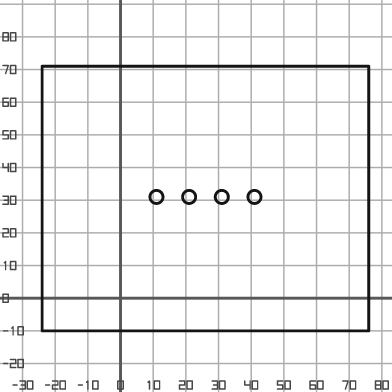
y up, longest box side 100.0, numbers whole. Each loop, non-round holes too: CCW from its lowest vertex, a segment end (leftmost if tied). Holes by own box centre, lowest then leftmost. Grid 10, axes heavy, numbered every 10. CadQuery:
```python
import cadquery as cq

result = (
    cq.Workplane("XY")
    .moveTo(-24.0, -10.0)
    .lineTo(76.0, -10.0)
    .lineTo(76.0, 71.0)
    .lineTo(-24.0, 71.0)
    .close()
    .moveTo(11.0, 31.0)
    .circle(2.0)
    .moveTo(21.0, 31.0)
    .circle(2.0)
    .moveTo(31.0, 31.0)
    .circle(2.0)
    .moveTo(41.0, 31.0)
    .circle(2.0)
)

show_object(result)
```